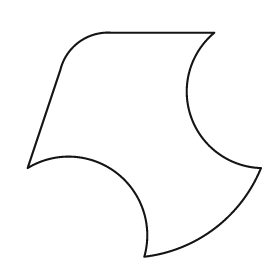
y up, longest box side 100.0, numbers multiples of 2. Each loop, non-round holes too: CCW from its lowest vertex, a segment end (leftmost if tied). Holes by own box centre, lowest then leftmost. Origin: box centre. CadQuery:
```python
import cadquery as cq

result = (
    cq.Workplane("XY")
    .moveTo(0.0, -48.0)
    .threePointArc((30.0, -36.0), (50.0, -10.0))
    .threePointArc((20.0, 12.0), (30.0, 48.0))
    .lineTo(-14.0, 48.0)
    .threePointArc((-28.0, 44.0), (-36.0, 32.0))
    .lineTo(-50.0, -10.0)
    .threePointArc((-12.0, -12.0), (0.0, -48.0))
    .close()
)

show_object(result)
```